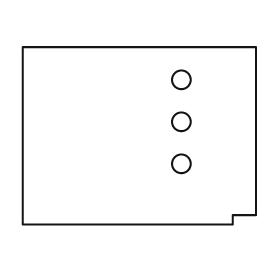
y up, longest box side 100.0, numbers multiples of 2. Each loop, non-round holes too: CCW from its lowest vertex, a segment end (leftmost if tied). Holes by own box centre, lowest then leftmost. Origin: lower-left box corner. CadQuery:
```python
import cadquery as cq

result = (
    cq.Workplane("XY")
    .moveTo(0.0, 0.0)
    .lineTo(90.0, 0.0)
    .lineTo(90.0, 4.0)
    .lineTo(100.0, 4.0)
    .lineTo(100.0, 76.0)
    .lineTo(0.0, 76.0)
    .close()
    .moveTo(68.0, 26.0)
    .circle(4.0)
    .moveTo(68.0, 44.0)
    .circle(4.0)
    .moveTo(68.0, 62.0)
    .circle(4.0)
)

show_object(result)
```